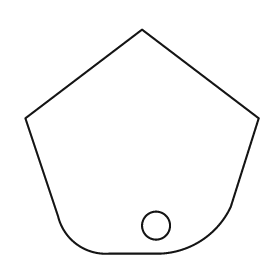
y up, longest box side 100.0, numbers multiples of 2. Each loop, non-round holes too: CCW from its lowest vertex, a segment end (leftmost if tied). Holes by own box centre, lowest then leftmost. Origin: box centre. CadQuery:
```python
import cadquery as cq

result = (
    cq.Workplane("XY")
    .moveTo(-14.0, -48.0)
    .lineTo(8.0, -48.0)
    .threePointArc((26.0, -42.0), (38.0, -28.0))
    .lineTo(50.0, 10.0)
    .lineTo(0.0, 48.0)
    .lineTo(-50.0, 10.0)
    .lineTo(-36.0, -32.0)
    .threePointArc((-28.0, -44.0), (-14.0, -48.0))
    .close()
    .moveTo(6.0, -36.0)
    .circle(6.0)
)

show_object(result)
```